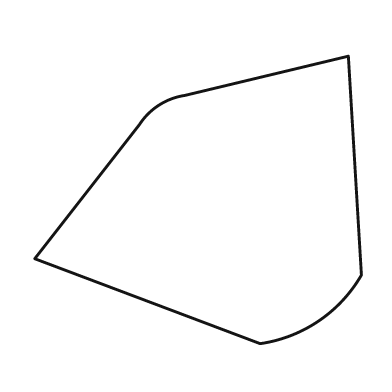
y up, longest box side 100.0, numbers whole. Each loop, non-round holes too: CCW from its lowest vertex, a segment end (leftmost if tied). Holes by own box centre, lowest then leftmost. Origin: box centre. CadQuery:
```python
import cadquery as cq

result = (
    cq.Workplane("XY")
    .moveTo(19.0, -44.0)
    .threePointArc((37.0, -37.0), (50.0, -23.0))
    .lineTo(46.0, 44.0)
    .lineTo(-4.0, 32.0)
    .threePointArc((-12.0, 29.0), (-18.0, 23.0))
    .lineTo(-50.0, -18.0)
    .close()
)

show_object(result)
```